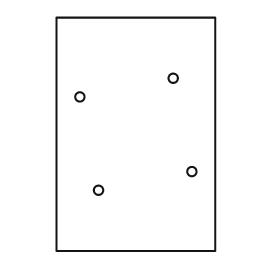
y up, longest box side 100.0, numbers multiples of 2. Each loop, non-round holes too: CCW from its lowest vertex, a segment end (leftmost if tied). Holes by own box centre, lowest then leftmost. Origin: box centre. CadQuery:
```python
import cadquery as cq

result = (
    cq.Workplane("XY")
    .moveTo(-34.0, -50.0)
    .lineTo(34.0, -50.0)
    .lineTo(34.0, 50.0)
    .lineTo(-34.0, 50.0)
    .close()
    .moveTo(-16.0, -24.0)
    .circle(2.0)
    .moveTo(24.0, -16.0)
    .circle(2.0)
    .moveTo(-24.0, 16.0)
    .circle(2.0)
    .moveTo(16.0, 24.0)
    .circle(2.0)
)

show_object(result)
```